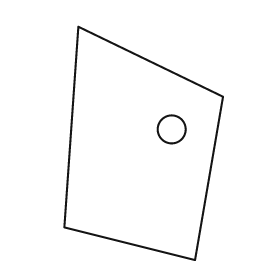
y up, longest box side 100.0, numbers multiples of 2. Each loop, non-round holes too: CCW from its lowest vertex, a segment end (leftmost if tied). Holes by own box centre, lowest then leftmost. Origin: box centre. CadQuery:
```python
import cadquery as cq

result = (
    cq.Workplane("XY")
    .moveTo(22.0, -50.0)
    .lineTo(34.0, 20.0)
    .lineTo(-28.0, 50.0)
    .lineTo(-34.0, -36.0)
    .close()
    .moveTo(12.0, 6.0)
    .circle(6.0)
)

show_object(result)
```